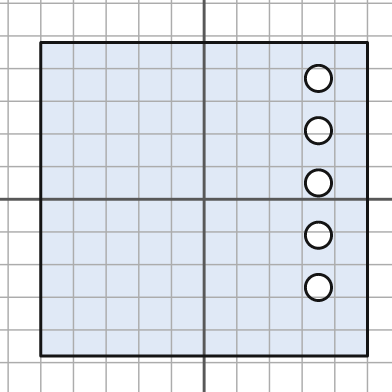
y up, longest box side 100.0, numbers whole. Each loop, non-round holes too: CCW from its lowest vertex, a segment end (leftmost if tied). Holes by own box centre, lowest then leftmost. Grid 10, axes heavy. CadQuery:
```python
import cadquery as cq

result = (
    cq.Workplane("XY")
    .moveTo(-50.0, -48.0)
    .lineTo(50.0, -48.0)
    .lineTo(50.0, 48.0)
    .lineTo(-50.0, 48.0)
    .close()
    .moveTo(35.0, -27.0)
    .circle(4.0)
    .moveTo(35.0, -11.0)
    .circle(4.0)
    .moveTo(35.0, 5.0)
    .circle(4.0)
    .moveTo(35.0, 21.0)
    .circle(4.0)
    .moveTo(35.0, 37.0)
    .circle(4.0)
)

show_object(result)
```